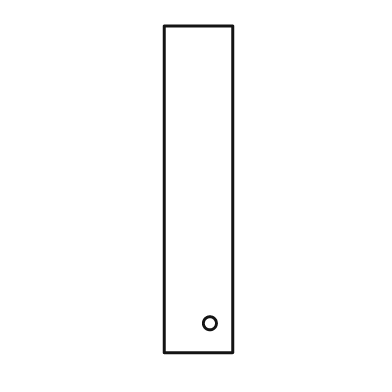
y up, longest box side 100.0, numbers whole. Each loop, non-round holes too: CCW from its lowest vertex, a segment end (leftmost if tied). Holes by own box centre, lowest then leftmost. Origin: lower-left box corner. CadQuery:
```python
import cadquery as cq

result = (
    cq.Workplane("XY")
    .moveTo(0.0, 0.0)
    .lineTo(21.0, 0.0)
    .lineTo(21.0, 100.0)
    .lineTo(0.0, 100.0)
    .close()
    .moveTo(14.0, 9.0)
    .circle(2.0)
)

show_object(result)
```